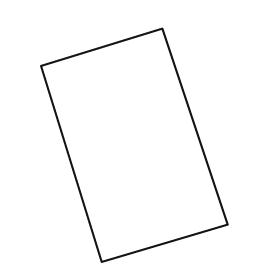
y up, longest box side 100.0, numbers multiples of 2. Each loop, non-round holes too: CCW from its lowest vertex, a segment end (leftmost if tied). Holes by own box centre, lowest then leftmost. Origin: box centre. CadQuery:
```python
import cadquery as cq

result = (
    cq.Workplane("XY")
    .moveTo(-14.0, -50.0)
    .lineTo(40.0, -34.0)
    .lineTo(12.0, 50.0)
    .lineTo(-40.0, 34.0)
    .close()
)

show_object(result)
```